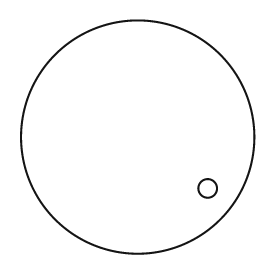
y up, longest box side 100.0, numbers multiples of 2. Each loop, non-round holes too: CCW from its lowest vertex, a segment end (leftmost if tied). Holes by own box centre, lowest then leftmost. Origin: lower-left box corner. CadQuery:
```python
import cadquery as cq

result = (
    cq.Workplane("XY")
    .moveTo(50.0, 50.0)
    .circle(50.0)
    .moveTo(80.0, 28.0)
    .circle(4.0)
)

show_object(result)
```